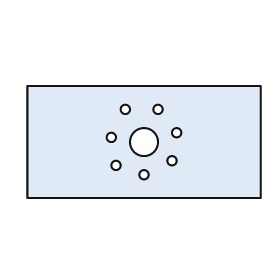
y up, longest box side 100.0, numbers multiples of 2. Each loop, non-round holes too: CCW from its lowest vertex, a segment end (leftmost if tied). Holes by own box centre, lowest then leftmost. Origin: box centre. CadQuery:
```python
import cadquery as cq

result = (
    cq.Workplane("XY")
    .moveTo(-50.0, -24.0)
    .lineTo(50.0, -24.0)
    .lineTo(50.0, 24.0)
    .lineTo(-50.0, 24.0)
    .close()
    .moveTo(0.0, -14.0)
    .circle(2.0)
    .moveTo(-12.0, -10.0)
    .circle(2.0)
    .moveTo(12.0, -8.0)
    .circle(2.0)
    .moveTo(0.0, 0.0)
    .circle(6.0)
    .moveTo(-14.0, 2.0)
    .circle(2.0)
    .moveTo(14.0, 4.0)
    .circle(2.0)
    .moveTo(-8.0, 14.0)
    .circle(2.0)
    .moveTo(6.0, 14.0)
    .circle(2.0)
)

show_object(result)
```